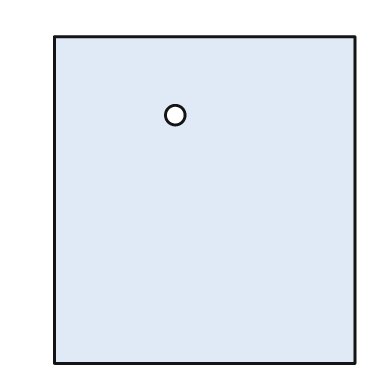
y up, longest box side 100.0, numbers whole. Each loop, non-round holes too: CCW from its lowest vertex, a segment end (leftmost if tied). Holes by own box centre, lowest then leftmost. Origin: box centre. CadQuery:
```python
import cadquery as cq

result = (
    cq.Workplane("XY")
    .moveTo(-46.0, -50.0)
    .lineTo(46.0, -50.0)
    .lineTo(46.0, 50.0)
    .lineTo(-46.0, 50.0)
    .close()
    .moveTo(-9.0, 26.0)
    .circle(3.0)
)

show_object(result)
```